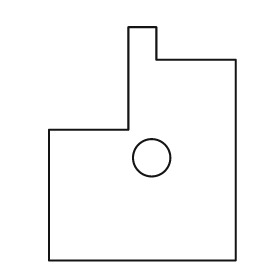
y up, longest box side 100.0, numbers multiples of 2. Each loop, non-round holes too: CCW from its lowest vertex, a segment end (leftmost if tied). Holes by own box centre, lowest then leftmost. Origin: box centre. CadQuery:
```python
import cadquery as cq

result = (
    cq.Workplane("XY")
    .moveTo(-40.0, -50.0)
    .lineTo(40.0, -50.0)
    .lineTo(40.0, 36.0)
    .lineTo(6.0, 36.0)
    .lineTo(6.0, 50.0)
    .lineTo(-6.0, 50.0)
    .lineTo(-6.0, 6.0)
    .lineTo(-40.0, 6.0)
    .close()
    .moveTo(4.0, -6.0)
    .circle(8.0)
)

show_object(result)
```